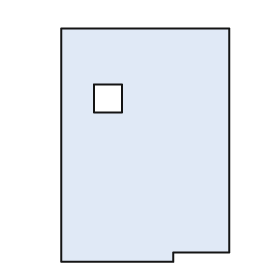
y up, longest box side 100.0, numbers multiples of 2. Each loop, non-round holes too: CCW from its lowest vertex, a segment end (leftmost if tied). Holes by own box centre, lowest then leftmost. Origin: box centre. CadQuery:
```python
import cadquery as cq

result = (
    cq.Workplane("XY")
    .moveTo(-36.0, -50.0)
    .lineTo(12.0, -50.0)
    .lineTo(12.0, -46.0)
    .lineTo(36.0, -46.0)
    .lineTo(36.0, 50.0)
    .lineTo(-36.0, 50.0)
    .close()
    .moveTo(-22.0, 14.0)
    .lineTo(-10.0, 14.0)
    .lineTo(-10.0, 26.0)
    .lineTo(-22.0, 26.0)
    .close()
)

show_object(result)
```